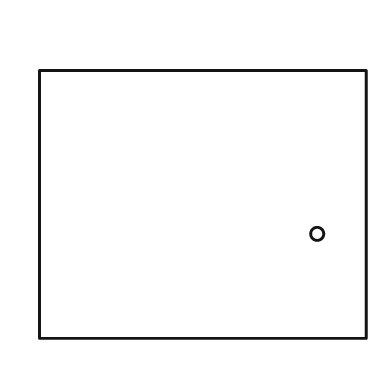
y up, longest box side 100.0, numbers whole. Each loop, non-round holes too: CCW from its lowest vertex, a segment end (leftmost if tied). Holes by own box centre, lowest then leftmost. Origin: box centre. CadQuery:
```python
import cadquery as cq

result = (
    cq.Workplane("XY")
    .moveTo(-50.0, -41.0)
    .lineTo(50.0, -41.0)
    .lineTo(50.0, 41.0)
    .lineTo(-50.0, 41.0)
    .close()
    .moveTo(35.0, -9.0)
    .circle(2.0)
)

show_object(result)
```